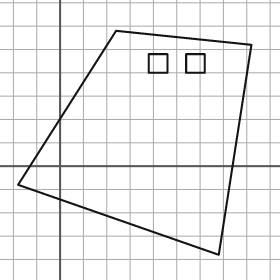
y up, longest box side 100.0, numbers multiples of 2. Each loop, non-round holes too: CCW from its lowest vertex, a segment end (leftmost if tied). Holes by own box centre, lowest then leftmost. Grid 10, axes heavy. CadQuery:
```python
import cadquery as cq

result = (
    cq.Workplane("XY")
    .moveTo(68.0, -38.0)
    .lineTo(82.0, 52.0)
    .lineTo(24.0, 58.0)
    .lineTo(-18.0, -8.0)
    .close()
    .moveTo(38.0, 40.0)
    .lineTo(46.0, 40.0)
    .lineTo(46.0, 48.0)
    .lineTo(38.0, 48.0)
    .close()
    .moveTo(54.0, 40.0)
    .lineTo(62.0, 40.0)
    .lineTo(62.0, 48.0)
    .lineTo(54.0, 48.0)
    .close()
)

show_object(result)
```